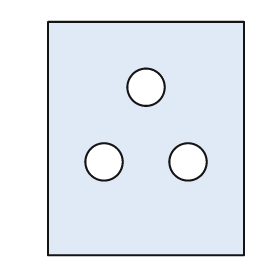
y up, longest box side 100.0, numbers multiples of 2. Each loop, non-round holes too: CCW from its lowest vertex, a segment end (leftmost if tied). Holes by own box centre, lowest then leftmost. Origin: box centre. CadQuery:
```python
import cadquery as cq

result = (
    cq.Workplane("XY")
    .moveTo(-42.0, -50.0)
    .lineTo(42.0, -50.0)
    .lineTo(42.0, 50.0)
    .lineTo(-42.0, 50.0)
    .close()
    .moveTo(-18.0, -10.0)
    .circle(8.0)
    .moveTo(18.0, -10.0)
    .circle(8.0)
    .moveTo(0.0, 22.0)
    .circle(8.0)
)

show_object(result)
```